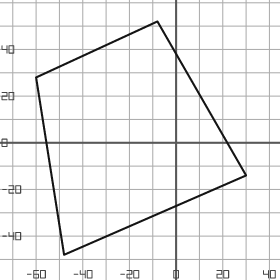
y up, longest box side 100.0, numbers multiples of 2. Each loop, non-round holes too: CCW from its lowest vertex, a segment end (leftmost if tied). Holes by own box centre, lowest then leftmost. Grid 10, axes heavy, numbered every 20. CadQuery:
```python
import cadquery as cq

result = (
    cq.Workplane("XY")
    .moveTo(-48.0, -48.0)
    .lineTo(30.0, -14.0)
    .lineTo(-8.0, 52.0)
    .lineTo(-60.0, 28.0)
    .close()
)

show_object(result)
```